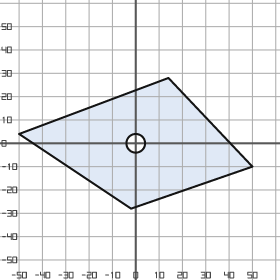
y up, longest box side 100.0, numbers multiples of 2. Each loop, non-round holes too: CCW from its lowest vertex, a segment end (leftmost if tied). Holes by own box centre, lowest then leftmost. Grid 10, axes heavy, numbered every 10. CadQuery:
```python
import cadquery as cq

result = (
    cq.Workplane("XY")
    .moveTo(-2.0, -28.0)
    .lineTo(50.0, -10.0)
    .lineTo(14.0, 28.0)
    .lineTo(-50.0, 4.0)
    .close()
    .moveTo(0.0, 0.0)
    .circle(4.0)
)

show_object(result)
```